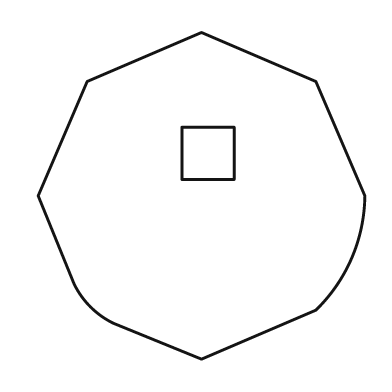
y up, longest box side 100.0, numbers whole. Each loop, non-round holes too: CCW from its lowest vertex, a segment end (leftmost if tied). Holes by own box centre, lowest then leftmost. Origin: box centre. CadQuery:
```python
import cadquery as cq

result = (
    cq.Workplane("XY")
    .moveTo(0.0, -50.0)
    .lineTo(35.0, -35.0)
    .threePointArc((46.0, -19.0), (50.0, 0.0))
    .lineTo(35.0, 35.0)
    .lineTo(0.0, 50.0)
    .lineTo(-35.0, 35.0)
    .lineTo(-50.0, 0.0)
    .lineTo(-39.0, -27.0)
    .threePointArc((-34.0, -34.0), (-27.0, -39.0))
    .close()
    .moveTo(-6.0, 5.0)
    .lineTo(10.0, 5.0)
    .lineTo(10.0, 21.0)
    .lineTo(-6.0, 21.0)
    .close()
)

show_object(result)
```